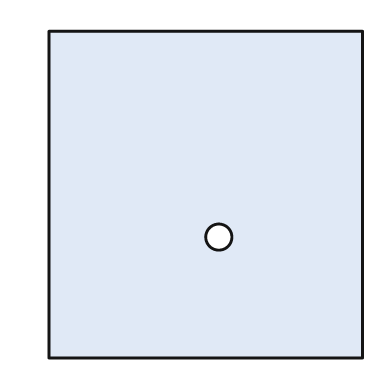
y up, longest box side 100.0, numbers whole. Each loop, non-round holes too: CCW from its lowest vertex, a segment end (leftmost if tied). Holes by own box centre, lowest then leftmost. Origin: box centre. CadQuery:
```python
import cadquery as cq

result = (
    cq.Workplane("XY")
    .moveTo(-48.0, -50.0)
    .lineTo(48.0, -50.0)
    .lineTo(48.0, 50.0)
    .lineTo(-48.0, 50.0)
    .close()
    .moveTo(4.0, -13.0)
    .circle(4.0)
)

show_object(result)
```